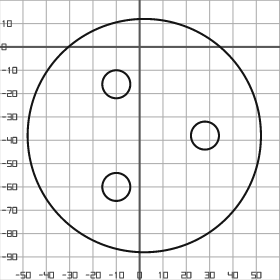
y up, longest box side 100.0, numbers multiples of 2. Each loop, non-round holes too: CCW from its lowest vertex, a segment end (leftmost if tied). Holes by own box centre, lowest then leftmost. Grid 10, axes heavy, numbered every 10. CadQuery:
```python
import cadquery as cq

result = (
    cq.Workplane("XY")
    .moveTo(2.0, -38.0)
    .circle(50.0)
    .moveTo(-10.0, -60.0)
    .circle(6.0)
    .moveTo(28.0, -38.0)
    .circle(6.0)
    .moveTo(-10.0, -16.0)
    .circle(6.0)
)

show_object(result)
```